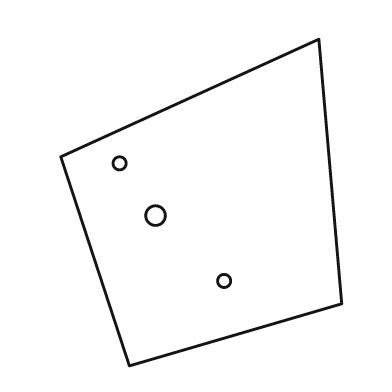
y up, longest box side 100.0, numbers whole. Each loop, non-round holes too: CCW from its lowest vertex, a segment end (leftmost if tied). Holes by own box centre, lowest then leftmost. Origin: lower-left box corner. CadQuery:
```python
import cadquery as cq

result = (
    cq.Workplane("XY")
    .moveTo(21.0, 0.0)
    .lineTo(86.0, 19.0)
    .lineTo(79.0, 100.0)
    .lineTo(0.0, 64.0)
    .close()
    .moveTo(50.0, 26.0)
    .circle(2.0)
    .moveTo(29.0, 46.0)
    .circle(3.0)
    .moveTo(18.0, 62.0)
    .circle(2.0)
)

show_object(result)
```